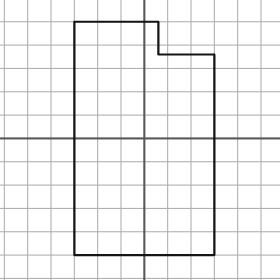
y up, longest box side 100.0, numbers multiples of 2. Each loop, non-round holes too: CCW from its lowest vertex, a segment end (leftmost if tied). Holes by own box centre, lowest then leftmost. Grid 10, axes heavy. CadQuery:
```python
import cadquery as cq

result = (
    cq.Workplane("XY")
    .moveTo(-30.0, -50.0)
    .lineTo(30.0, -50.0)
    .lineTo(30.0, 36.0)
    .lineTo(6.0, 36.0)
    .lineTo(6.0, 50.0)
    .lineTo(-30.0, 50.0)
    .close()
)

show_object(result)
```